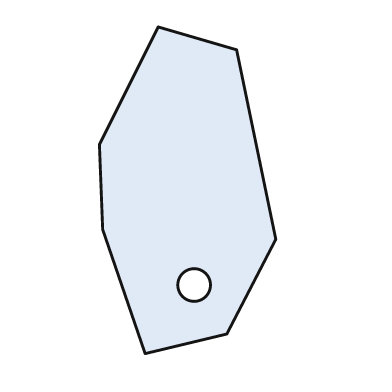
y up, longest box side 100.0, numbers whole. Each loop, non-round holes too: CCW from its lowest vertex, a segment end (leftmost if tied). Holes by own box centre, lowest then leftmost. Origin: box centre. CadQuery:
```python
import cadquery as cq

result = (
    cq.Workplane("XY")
    .moveTo(-13.0, -50.0)
    .lineTo(12.0, -44.0)
    .lineTo(27.0, -15.0)
    .lineTo(15.0, 43.0)
    .lineTo(-9.0, 50.0)
    .lineTo(-27.0, 14.0)
    .lineTo(-26.0, -12.0)
    .close()
    .moveTo(2.0, -29.0)
    .circle(5.0)
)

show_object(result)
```